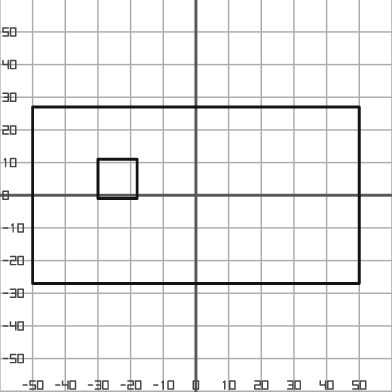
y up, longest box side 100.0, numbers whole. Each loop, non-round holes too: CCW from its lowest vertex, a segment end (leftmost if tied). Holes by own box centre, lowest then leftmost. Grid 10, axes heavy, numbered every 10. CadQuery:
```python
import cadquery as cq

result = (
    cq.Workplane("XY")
    .moveTo(-50.0, -27.0)
    .lineTo(50.0, -27.0)
    .lineTo(50.0, 27.0)
    .lineTo(-50.0, 27.0)
    .close()
    .moveTo(-30.0, -1.0)
    .lineTo(-18.0, -1.0)
    .lineTo(-18.0, 11.0)
    .lineTo(-30.0, 11.0)
    .close()
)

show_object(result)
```